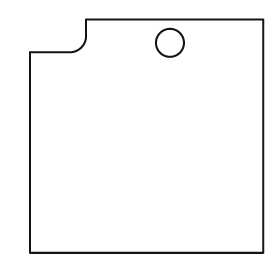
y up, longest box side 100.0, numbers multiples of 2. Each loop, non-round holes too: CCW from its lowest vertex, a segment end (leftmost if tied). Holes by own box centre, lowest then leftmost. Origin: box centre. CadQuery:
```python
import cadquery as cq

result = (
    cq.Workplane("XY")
    .moveTo(-50.0, -50.0)
    .lineTo(50.0, -50.0)
    .lineTo(50.0, 50.0)
    .lineTo(-26.0, 50.0)
    .lineTo(-26.0, 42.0)
    .threePointArc((-28.0, 38.0), (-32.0, 36.0))
    .lineTo(-50.0, 36.0)
    .close()
    .moveTo(10.0, 40.0)
    .circle(6.0)
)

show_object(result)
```